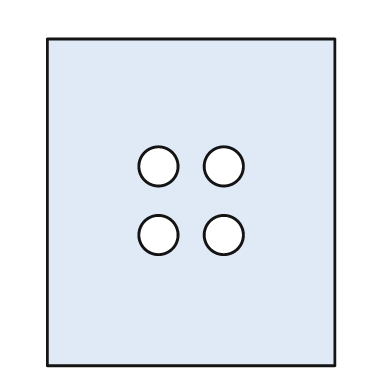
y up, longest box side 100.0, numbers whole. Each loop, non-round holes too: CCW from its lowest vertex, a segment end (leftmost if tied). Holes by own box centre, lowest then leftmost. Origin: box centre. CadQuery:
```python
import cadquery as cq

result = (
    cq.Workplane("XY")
    .moveTo(-44.0, -50.0)
    .lineTo(44.0, -50.0)
    .lineTo(44.0, 50.0)
    .lineTo(-44.0, 50.0)
    .close()
    .moveTo(-10.0, -10.0)
    .circle(6.0)
    .moveTo(10.0, -10.0)
    .circle(6.0)
    .moveTo(-10.0, 11.0)
    .circle(6.0)
    .moveTo(10.0, 11.0)
    .circle(6.0)
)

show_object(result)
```